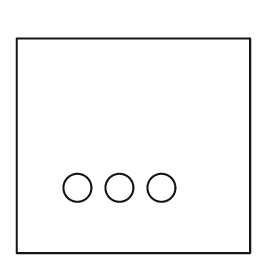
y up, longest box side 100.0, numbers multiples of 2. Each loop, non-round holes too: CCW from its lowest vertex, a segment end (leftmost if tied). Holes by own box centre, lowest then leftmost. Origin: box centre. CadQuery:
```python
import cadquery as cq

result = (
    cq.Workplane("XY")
    .moveTo(-50.0, -46.0)
    .lineTo(50.0, -46.0)
    .lineTo(50.0, 46.0)
    .lineTo(-50.0, 46.0)
    .close()
    .moveTo(-24.0, -18.0)
    .circle(6.0)
    .moveTo(-6.0, -18.0)
    .circle(6.0)
    .moveTo(12.0, -18.0)
    .circle(6.0)
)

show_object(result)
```